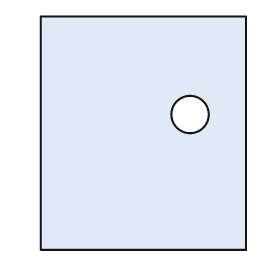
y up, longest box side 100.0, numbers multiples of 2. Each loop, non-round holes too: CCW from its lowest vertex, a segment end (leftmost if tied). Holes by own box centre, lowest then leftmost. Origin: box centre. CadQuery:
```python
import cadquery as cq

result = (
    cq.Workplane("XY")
    .moveTo(-44.0, -50.0)
    .lineTo(44.0, -50.0)
    .lineTo(44.0, 50.0)
    .lineTo(-44.0, 50.0)
    .close()
    .moveTo(20.0, 8.0)
    .circle(8.0)
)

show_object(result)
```